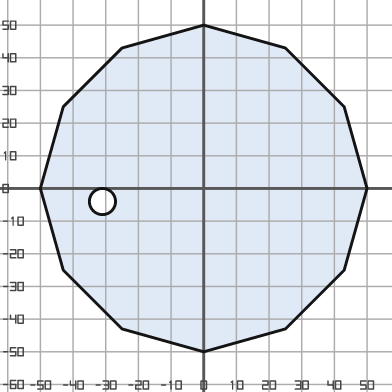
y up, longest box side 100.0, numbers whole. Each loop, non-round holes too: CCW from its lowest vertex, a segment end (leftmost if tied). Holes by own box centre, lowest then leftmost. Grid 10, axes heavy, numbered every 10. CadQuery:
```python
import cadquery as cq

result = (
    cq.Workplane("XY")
    .moveTo(0.0, -50.0)
    .lineTo(25.0, -43.0)
    .lineTo(43.0, -25.0)
    .lineTo(50.0, 0.0)
    .lineTo(43.0, 25.0)
    .lineTo(25.0, 43.0)
    .lineTo(0.0, 50.0)
    .lineTo(-25.0, 43.0)
    .lineTo(-43.0, 25.0)
    .lineTo(-50.0, 0.0)
    .lineTo(-43.0, -25.0)
    .lineTo(-25.0, -43.0)
    .close()
    .moveTo(-31.0, -4.0)
    .circle(4.0)
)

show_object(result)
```